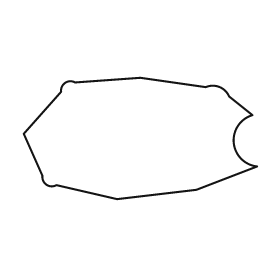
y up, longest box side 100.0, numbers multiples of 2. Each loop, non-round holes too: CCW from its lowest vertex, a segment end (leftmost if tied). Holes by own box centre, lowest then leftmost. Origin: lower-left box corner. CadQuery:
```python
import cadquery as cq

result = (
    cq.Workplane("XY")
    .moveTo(40.0, 0.0)
    .lineTo(74.0, 4.0)
    .lineTo(100.0, 14.0)
    .threePointArc((90.0, 24.0), (98.0, 36.0))
    .lineTo(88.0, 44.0)
    .threePointArc((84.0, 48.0), (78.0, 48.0))
    .lineTo(50.0, 52.0)
    .lineTo(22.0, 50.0)
    .threePointArc((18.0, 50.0), (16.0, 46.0))
    .lineTo(0.0, 28.0)
    .lineTo(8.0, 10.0)
    .threePointArc((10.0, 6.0), (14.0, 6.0))
    .close()
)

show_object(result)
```